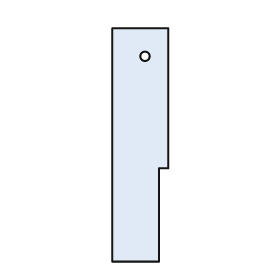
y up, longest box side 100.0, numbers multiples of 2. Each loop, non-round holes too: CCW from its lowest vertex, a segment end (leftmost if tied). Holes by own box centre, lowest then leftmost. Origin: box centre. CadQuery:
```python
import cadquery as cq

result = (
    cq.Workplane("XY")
    .moveTo(-12.0, -50.0)
    .lineTo(8.0, -50.0)
    .lineTo(8.0, -10.0)
    .lineTo(12.0, -10.0)
    .lineTo(12.0, 50.0)
    .lineTo(-12.0, 50.0)
    .close()
    .moveTo(2.0, 38.0)
    .circle(2.0)
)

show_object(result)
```